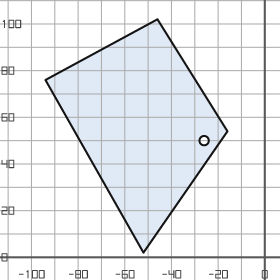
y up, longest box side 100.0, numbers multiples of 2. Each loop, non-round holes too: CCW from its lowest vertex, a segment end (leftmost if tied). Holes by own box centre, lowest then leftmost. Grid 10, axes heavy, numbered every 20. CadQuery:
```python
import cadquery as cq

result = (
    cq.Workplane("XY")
    .moveTo(-52.0, 2.0)
    .lineTo(-16.0, 54.0)
    .lineTo(-46.0, 102.0)
    .lineTo(-94.0, 76.0)
    .close()
    .moveTo(-26.0, 50.0)
    .circle(2.0)
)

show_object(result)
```